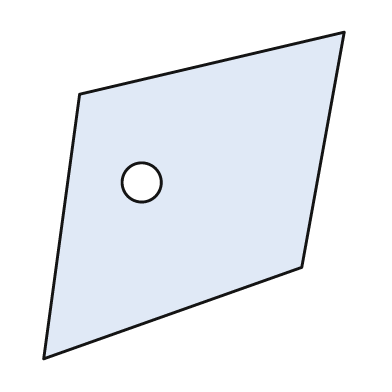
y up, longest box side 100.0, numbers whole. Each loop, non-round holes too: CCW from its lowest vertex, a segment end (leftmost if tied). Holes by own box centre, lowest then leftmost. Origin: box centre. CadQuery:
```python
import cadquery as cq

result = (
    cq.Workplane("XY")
    .moveTo(-46.0, -50.0)
    .lineTo(33.0, -22.0)
    .lineTo(46.0, 50.0)
    .lineTo(-35.0, 31.0)
    .close()
    .moveTo(-16.0, 4.0)
    .circle(6.0)
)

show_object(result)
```